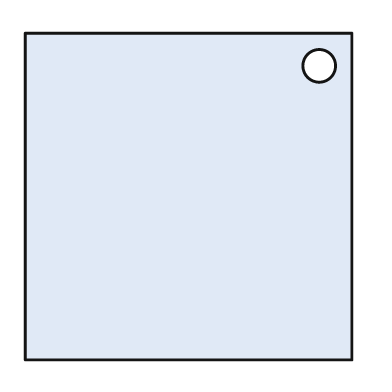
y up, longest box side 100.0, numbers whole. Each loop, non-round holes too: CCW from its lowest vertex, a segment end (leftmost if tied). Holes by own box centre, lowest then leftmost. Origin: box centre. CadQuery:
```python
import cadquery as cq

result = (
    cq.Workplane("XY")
    .moveTo(-50.0, -50.0)
    .lineTo(50.0, -50.0)
    .lineTo(50.0, 50.0)
    .lineTo(-50.0, 50.0)
    .close()
    .moveTo(40.0, 40.0)
    .circle(5.0)
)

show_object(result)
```